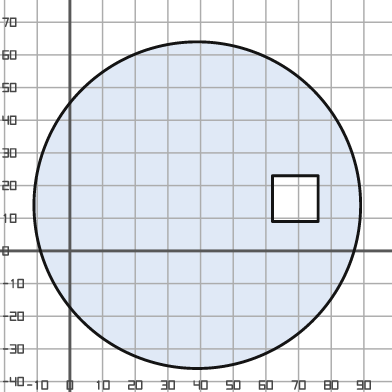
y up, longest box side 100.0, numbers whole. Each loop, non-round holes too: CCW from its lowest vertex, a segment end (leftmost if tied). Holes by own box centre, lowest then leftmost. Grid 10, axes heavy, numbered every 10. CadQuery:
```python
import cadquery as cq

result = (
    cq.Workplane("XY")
    .moveTo(39.0, 14.0)
    .circle(50.0)
    .moveTo(62.0, 9.0)
    .lineTo(76.0, 9.0)
    .lineTo(76.0, 23.0)
    .lineTo(62.0, 23.0)
    .close()
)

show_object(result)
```